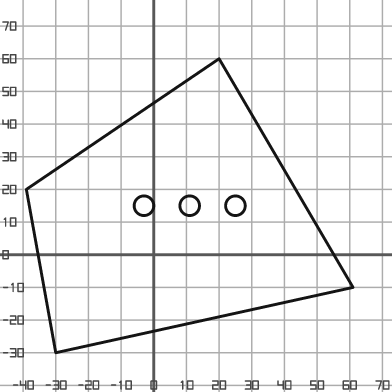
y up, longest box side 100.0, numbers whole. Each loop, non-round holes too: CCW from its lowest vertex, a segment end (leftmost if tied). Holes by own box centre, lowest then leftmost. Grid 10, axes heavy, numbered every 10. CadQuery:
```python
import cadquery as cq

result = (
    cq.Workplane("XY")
    .moveTo(-30.0, -30.0)
    .lineTo(61.0, -10.0)
    .lineTo(20.0, 60.0)
    .lineTo(-39.0, 20.0)
    .close()
    .moveTo(-3.0, 15.0)
    .circle(3.0)
    .moveTo(11.0, 15.0)
    .circle(3.0)
    .moveTo(25.0, 15.0)
    .circle(3.0)
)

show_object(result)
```